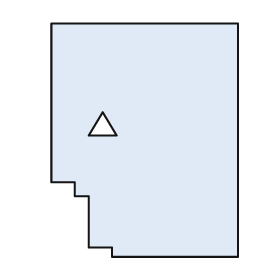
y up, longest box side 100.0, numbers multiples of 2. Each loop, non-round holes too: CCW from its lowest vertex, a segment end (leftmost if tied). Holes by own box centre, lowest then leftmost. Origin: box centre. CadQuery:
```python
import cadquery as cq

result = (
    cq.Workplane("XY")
    .moveTo(-14.0, -50.0)
    .lineTo(40.0, -50.0)
    .lineTo(40.0, 50.0)
    .lineTo(-40.0, 50.0)
    .lineTo(-40.0, -18.0)
    .lineTo(-30.0, -18.0)
    .lineTo(-30.0, -24.0)
    .lineTo(-24.0, -24.0)
    .lineTo(-24.0, -46.0)
    .lineTo(-14.0, -46.0)
    .close()
    .moveTo(-24.0, 2.0)
    .lineTo(-12.0, 2.0)
    .lineTo(-18.0, 12.0)
    .close()
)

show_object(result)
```